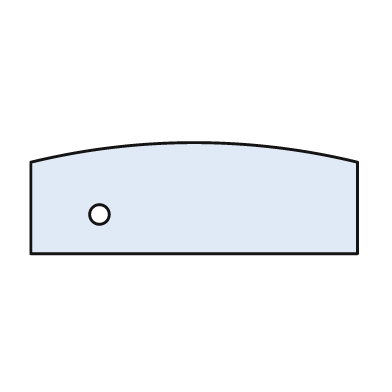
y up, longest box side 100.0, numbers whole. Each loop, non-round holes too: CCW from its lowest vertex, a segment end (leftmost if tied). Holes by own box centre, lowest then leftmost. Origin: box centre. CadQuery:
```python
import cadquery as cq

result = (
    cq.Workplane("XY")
    .moveTo(-50.0, -17.0)
    .lineTo(50.0, -17.0)
    .lineTo(50.0, 11.0)
    .threePointArc((0.0, 17.0), (-50.0, 11.0))
    .close()
    .moveTo(-29.0, -5.0)
    .circle(3.0)
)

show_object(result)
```